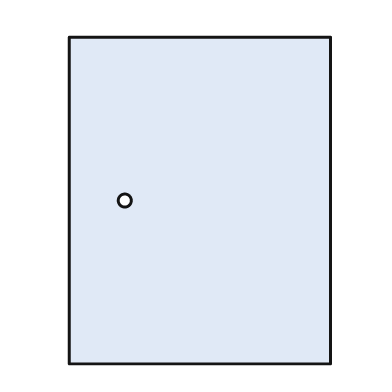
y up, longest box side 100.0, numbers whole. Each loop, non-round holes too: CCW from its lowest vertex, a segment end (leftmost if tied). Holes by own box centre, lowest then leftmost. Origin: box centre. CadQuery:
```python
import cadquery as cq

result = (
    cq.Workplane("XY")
    .moveTo(-40.0, -50.0)
    .lineTo(40.0, -50.0)
    .lineTo(40.0, 50.0)
    .lineTo(-40.0, 50.0)
    .close()
    .moveTo(-23.0, 0.0)
    .circle(2.0)
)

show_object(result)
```